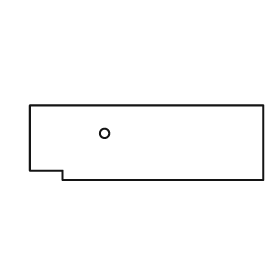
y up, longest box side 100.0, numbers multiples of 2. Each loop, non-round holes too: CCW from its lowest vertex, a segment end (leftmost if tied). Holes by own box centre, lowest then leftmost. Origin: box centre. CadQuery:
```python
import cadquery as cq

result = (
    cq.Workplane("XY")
    .moveTo(-36.0, -16.0)
    .lineTo(50.0, -16.0)
    .lineTo(50.0, 16.0)
    .lineTo(-50.0, 16.0)
    .lineTo(-50.0, -12.0)
    .lineTo(-36.0, -12.0)
    .close()
    .moveTo(-18.0, 4.0)
    .circle(2.0)
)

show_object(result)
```